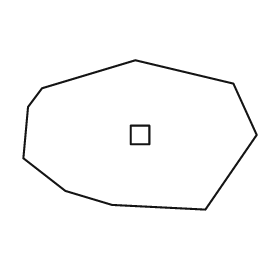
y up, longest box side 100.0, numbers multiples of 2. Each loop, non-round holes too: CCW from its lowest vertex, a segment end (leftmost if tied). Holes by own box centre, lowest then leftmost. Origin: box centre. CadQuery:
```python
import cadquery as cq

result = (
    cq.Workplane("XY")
    .moveTo(28.0, -32.0)
    .lineTo(50.0, 0.0)
    .lineTo(40.0, 22.0)
    .lineTo(-2.0, 32.0)
    .lineTo(-42.0, 20.0)
    .lineTo(-48.0, 12.0)
    .lineTo(-50.0, -10.0)
    .lineTo(-32.0, -24.0)
    .lineTo(-12.0, -30.0)
    .close()
    .moveTo(-4.0, -4.0)
    .lineTo(4.0, -4.0)
    .lineTo(4.0, 4.0)
    .lineTo(-4.0, 4.0)
    .close()
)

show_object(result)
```